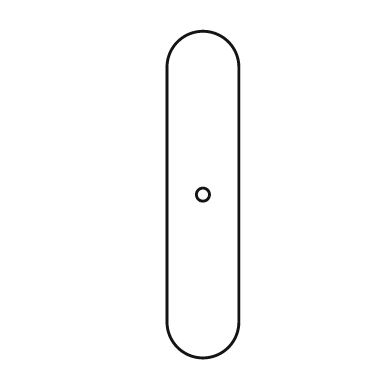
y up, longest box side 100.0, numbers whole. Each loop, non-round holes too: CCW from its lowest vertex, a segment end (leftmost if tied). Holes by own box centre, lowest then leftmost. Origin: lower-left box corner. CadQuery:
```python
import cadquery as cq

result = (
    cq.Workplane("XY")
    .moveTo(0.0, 11.0)
    .threePointArc((11.0, 0.0), (22.0, 11.0))
    .lineTo(22.0, 89.0)
    .threePointArc((11.0, 100.0), (0.0, 89.0))
    .close()
    .moveTo(11.0, 50.0)
    .circle(2.0)
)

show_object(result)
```